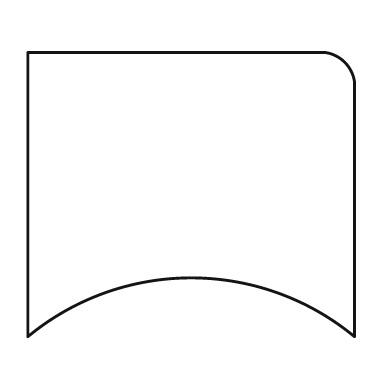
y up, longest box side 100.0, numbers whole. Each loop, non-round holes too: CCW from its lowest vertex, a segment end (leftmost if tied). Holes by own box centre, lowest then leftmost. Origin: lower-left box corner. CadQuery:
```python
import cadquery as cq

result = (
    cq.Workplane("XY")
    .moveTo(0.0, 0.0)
    .threePointArc((50.0, 18.0), (100.0, 0.0))
    .lineTo(100.0, 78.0)
    .threePointArc((97.0, 84.0), (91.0, 87.0))
    .lineTo(0.0, 87.0)
    .close()
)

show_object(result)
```